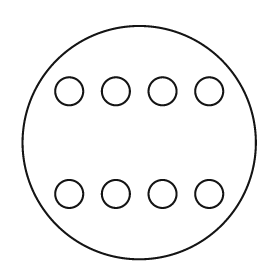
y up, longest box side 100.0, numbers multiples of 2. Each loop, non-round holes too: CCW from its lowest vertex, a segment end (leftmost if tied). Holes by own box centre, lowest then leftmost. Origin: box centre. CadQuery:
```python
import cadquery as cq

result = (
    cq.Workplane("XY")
    .moveTo(0.0, 0.0)
    .circle(50.0)
    .moveTo(-30.0, -22.0)
    .circle(6.0)
    .moveTo(-10.0, -22.0)
    .circle(6.0)
    .moveTo(10.0, -22.0)
    .circle(6.0)
    .moveTo(30.0, -22.0)
    .circle(6.0)
    .moveTo(-30.0, 22.0)
    .circle(6.0)
    .moveTo(-10.0, 22.0)
    .circle(6.0)
    .moveTo(10.0, 22.0)
    .circle(6.0)
    .moveTo(30.0, 22.0)
    .circle(6.0)
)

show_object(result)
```